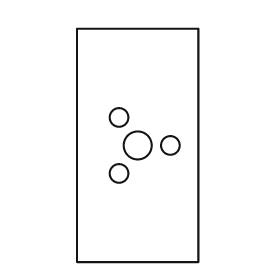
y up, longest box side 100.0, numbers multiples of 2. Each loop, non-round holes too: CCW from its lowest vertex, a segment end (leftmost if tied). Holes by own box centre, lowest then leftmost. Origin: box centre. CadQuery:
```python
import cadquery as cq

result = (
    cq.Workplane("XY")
    .moveTo(-26.0, -50.0)
    .lineTo(26.0, -50.0)
    .lineTo(26.0, 50.0)
    .lineTo(-26.0, 50.0)
    .close()
    .moveTo(-8.0, -12.0)
    .circle(4.0)
    .moveTo(0.0, 0.0)
    .circle(6.0)
    .moveTo(14.0, 0.0)
    .circle(4.0)
    .moveTo(-8.0, 12.0)
    .circle(4.0)
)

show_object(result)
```